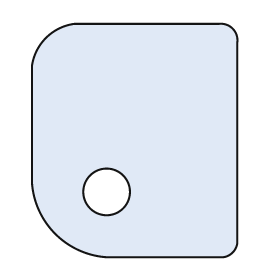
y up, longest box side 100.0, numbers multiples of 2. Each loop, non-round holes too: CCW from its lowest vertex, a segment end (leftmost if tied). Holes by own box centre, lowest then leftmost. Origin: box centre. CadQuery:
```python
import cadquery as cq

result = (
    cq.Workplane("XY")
    .moveTo(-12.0, -50.0)
    .lineTo(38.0, -50.0)
    .threePointArc((42.0, -48.0), (44.0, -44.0))
    .lineTo(44.0, 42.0)
    .threePointArc((42.0, 48.0), (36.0, 50.0))
    .lineTo(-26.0, 50.0)
    .threePointArc((-38.0, 44.0), (-44.0, 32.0))
    .lineTo(-44.0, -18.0)
    .threePointArc((-34.0, -40.0), (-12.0, -50.0))
    .close()
    .moveTo(-12.0, -22.0)
    .circle(10.0)
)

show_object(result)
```